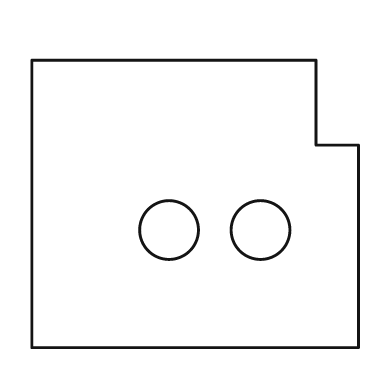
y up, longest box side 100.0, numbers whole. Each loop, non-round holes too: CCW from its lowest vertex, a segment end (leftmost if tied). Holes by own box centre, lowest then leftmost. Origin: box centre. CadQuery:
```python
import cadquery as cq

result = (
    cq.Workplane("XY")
    .moveTo(-50.0, -44.0)
    .lineTo(50.0, -44.0)
    .lineTo(50.0, 18.0)
    .lineTo(37.0, 18.0)
    .lineTo(37.0, 44.0)
    .lineTo(-50.0, 44.0)
    .close()
    .moveTo(-8.0, -8.0)
    .circle(9.0)
    .moveTo(20.0, -8.0)
    .circle(9.0)
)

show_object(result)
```